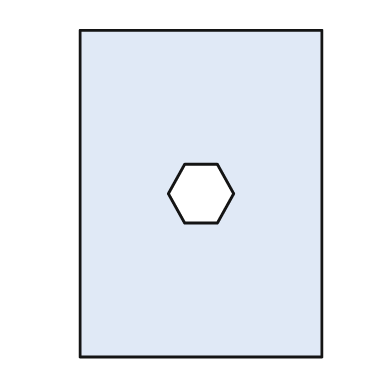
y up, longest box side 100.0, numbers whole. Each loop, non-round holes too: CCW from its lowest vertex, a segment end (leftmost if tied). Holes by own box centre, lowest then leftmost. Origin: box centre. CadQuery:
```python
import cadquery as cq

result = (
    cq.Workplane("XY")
    .moveTo(-37.0, -50.0)
    .lineTo(37.0, -50.0)
    .lineTo(37.0, 50.0)
    .lineTo(-37.0, 50.0)
    .close()
    .moveTo(-5.0, -9.0)
    .lineTo(5.0, -9.0)
    .lineTo(10.0, 0.0)
    .lineTo(5.0, 9.0)
    .lineTo(-5.0, 9.0)
    .lineTo(-10.0, 0.0)
    .close()
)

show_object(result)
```